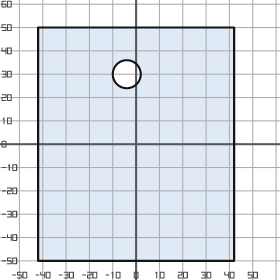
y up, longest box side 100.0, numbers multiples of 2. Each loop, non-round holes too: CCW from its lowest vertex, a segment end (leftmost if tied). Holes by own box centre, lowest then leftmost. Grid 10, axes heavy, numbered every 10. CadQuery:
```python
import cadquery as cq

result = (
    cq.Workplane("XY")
    .moveTo(-42.0, -50.0)
    .lineTo(42.0, -50.0)
    .lineTo(42.0, 50.0)
    .lineTo(-42.0, 50.0)
    .close()
    .moveTo(-4.0, 30.0)
    .circle(6.0)
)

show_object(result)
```